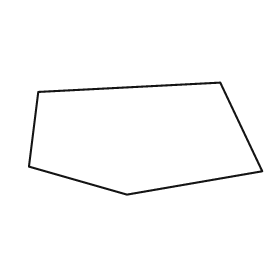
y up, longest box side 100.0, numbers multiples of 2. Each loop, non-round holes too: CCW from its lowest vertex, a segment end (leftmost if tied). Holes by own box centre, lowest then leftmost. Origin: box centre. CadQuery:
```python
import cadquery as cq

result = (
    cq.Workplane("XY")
    .moveTo(-8.0, -24.0)
    .lineTo(50.0, -14.0)
    .lineTo(32.0, 24.0)
    .lineTo(-46.0, 20.0)
    .lineTo(-50.0, -12.0)
    .close()
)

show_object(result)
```